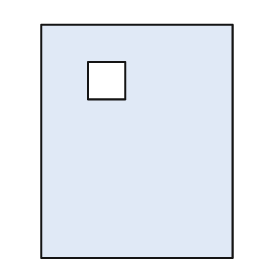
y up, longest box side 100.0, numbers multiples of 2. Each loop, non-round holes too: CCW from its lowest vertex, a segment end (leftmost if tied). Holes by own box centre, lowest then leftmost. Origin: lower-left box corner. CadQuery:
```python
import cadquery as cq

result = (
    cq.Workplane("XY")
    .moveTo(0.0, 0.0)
    .lineTo(82.0, 0.0)
    .lineTo(82.0, 100.0)
    .lineTo(0.0, 100.0)
    .close()
    .moveTo(20.0, 68.0)
    .lineTo(36.0, 68.0)
    .lineTo(36.0, 84.0)
    .lineTo(20.0, 84.0)
    .close()
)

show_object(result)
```